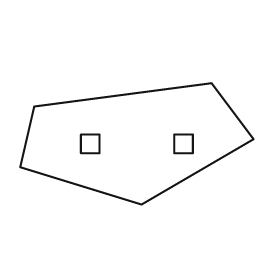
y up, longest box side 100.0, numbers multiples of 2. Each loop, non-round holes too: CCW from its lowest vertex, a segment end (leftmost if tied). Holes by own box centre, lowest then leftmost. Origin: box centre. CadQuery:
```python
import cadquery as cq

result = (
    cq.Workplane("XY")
    .moveTo(2.0, -26.0)
    .lineTo(50.0, 2.0)
    .lineTo(32.0, 26.0)
    .lineTo(-44.0, 16.0)
    .lineTo(-50.0, -10.0)
    .close()
    .moveTo(-24.0, -4.0)
    .lineTo(-16.0, -4.0)
    .lineTo(-16.0, 4.0)
    .lineTo(-24.0, 4.0)
    .close()
    .moveTo(16.0, -4.0)
    .lineTo(24.0, -4.0)
    .lineTo(24.0, 4.0)
    .lineTo(16.0, 4.0)
    .close()
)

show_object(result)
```